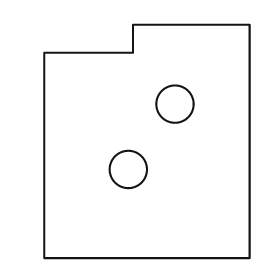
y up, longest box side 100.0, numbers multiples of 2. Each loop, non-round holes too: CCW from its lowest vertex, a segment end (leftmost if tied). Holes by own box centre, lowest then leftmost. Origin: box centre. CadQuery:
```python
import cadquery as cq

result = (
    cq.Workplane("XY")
    .moveTo(-44.0, -50.0)
    .lineTo(44.0, -50.0)
    .lineTo(44.0, 50.0)
    .lineTo(-6.0, 50.0)
    .lineTo(-6.0, 38.0)
    .lineTo(-44.0, 38.0)
    .close()
    .moveTo(-8.0, -12.0)
    .circle(8.0)
    .moveTo(12.0, 16.0)
    .circle(8.0)
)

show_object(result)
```